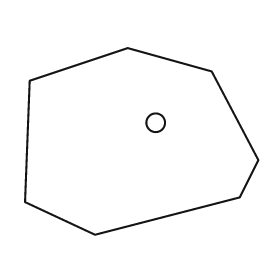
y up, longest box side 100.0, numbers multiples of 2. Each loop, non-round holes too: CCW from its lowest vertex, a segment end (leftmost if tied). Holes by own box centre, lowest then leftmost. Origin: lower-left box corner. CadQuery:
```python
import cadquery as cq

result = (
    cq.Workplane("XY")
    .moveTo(30.0, 0.0)
    .lineTo(92.0, 16.0)
    .lineTo(100.0, 32.0)
    .lineTo(80.0, 70.0)
    .lineTo(44.0, 80.0)
    .lineTo(2.0, 66.0)
    .lineTo(0.0, 14.0)
    .close()
    .moveTo(56.0, 48.0)
    .circle(4.0)
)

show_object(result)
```